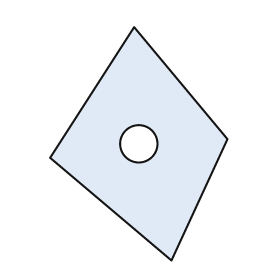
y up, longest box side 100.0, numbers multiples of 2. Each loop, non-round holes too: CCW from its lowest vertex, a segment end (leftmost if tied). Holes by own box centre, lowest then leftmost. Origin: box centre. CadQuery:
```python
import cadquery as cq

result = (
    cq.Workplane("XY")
    .moveTo(14.0, -50.0)
    .lineTo(38.0, 2.0)
    .lineTo(-2.0, 50.0)
    .lineTo(-38.0, -6.0)
    .close()
    .moveTo(0.0, 0.0)
    .circle(8.0)
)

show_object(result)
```